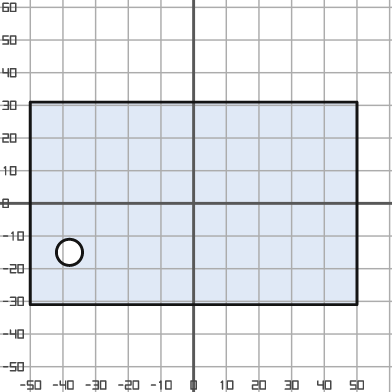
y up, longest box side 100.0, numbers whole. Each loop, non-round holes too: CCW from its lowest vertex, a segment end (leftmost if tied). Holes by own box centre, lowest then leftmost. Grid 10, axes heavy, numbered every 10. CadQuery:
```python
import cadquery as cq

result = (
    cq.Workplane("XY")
    .moveTo(-50.0, -31.0)
    .lineTo(50.0, -31.0)
    .lineTo(50.0, 31.0)
    .lineTo(-50.0, 31.0)
    .close()
    .moveTo(-38.0, -15.0)
    .circle(4.0)
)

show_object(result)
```